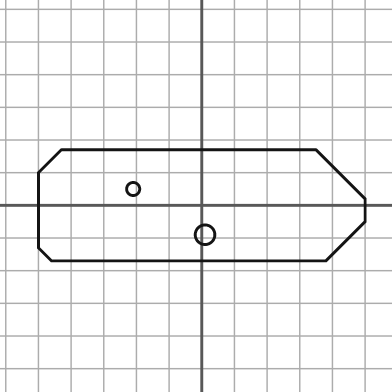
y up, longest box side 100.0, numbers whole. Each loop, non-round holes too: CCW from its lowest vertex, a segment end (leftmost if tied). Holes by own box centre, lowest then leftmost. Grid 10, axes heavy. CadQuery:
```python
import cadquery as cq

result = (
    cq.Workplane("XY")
    .moveTo(-46.0, -17.0)
    .lineTo(38.0, -17.0)
    .lineTo(50.0, -5.0)
    .lineTo(50.0, 2.0)
    .lineTo(35.0, 17.0)
    .lineTo(-43.0, 17.0)
    .lineTo(-50.0, 10.0)
    .lineTo(-50.0, -13.0)
    .close()
    .moveTo(1.0, -9.0)
    .circle(3.0)
    .moveTo(-21.0, 5.0)
    .circle(2.0)
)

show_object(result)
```